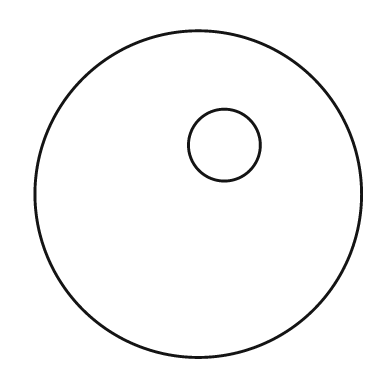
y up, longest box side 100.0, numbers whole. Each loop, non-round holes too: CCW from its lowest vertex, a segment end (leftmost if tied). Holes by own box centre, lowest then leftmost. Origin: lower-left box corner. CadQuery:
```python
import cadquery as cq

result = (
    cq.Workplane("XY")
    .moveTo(50.0, 50.0)
    .circle(50.0)
    .moveTo(58.0, 65.0)
    .circle(11.0)
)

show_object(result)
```